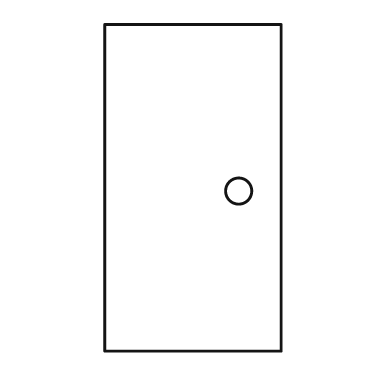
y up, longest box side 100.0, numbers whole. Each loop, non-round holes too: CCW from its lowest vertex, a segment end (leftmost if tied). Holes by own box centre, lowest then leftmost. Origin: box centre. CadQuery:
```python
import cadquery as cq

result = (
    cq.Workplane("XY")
    .moveTo(-27.0, -50.0)
    .lineTo(27.0, -50.0)
    .lineTo(27.0, 50.0)
    .lineTo(-27.0, 50.0)
    .close()
    .moveTo(14.0, -1.0)
    .circle(4.0)
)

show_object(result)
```